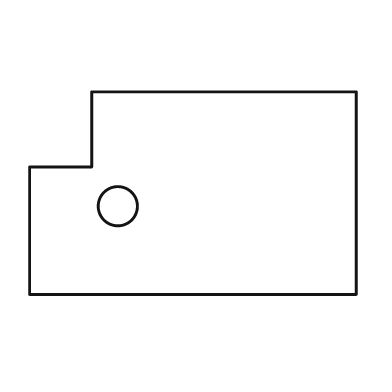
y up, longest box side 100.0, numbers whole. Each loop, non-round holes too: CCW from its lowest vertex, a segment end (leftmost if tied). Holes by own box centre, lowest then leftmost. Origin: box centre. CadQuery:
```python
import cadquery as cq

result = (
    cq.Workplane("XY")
    .moveTo(-50.0, -31.0)
    .lineTo(50.0, -31.0)
    .lineTo(50.0, 31.0)
    .lineTo(-31.0, 31.0)
    .lineTo(-31.0, 8.0)
    .lineTo(-50.0, 8.0)
    .close()
    .moveTo(-23.0, -4.0)
    .circle(6.0)
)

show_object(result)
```